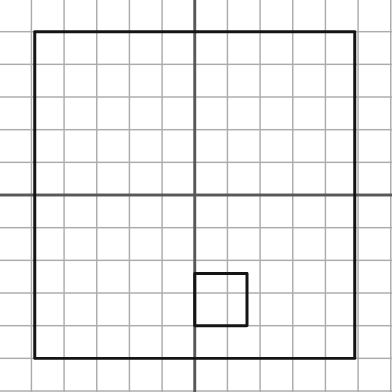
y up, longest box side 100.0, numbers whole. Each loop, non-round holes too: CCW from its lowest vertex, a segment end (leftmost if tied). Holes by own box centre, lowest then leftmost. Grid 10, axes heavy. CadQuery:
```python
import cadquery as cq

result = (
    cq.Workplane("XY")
    .moveTo(-49.0, -50.0)
    .lineTo(49.0, -50.0)
    .lineTo(49.0, 50.0)
    .lineTo(-49.0, 50.0)
    .close()
    .moveTo(0.0, -40.0)
    .lineTo(16.0, -40.0)
    .lineTo(16.0, -24.0)
    .lineTo(0.0, -24.0)
    .close()
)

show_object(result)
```